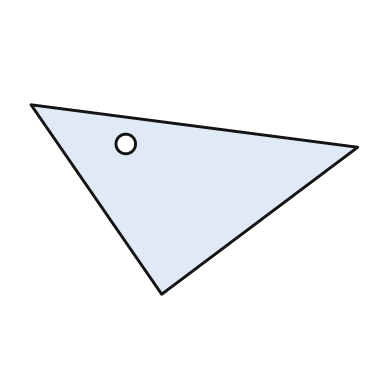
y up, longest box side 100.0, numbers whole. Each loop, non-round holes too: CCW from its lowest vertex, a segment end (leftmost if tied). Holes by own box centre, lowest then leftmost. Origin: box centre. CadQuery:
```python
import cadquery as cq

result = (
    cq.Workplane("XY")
    .moveTo(-10.0, -29.0)
    .lineTo(50.0, 16.0)
    .lineTo(-50.0, 29.0)
    .close()
    .moveTo(-21.0, 17.0)
    .circle(3.0)
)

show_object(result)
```